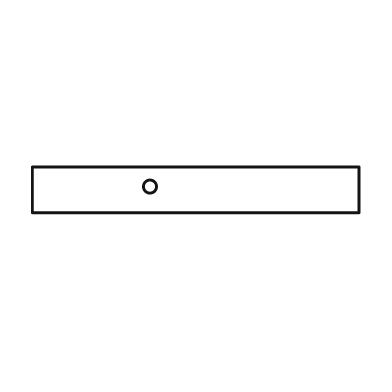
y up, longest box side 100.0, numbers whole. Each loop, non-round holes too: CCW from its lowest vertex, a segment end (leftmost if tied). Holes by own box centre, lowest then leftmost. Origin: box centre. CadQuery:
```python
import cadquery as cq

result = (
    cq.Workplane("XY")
    .moveTo(-50.0, -7.0)
    .lineTo(50.0, -7.0)
    .lineTo(50.0, 7.0)
    .lineTo(-50.0, 7.0)
    .close()
    .moveTo(-14.0, 1.0)
    .circle(2.0)
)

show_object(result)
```